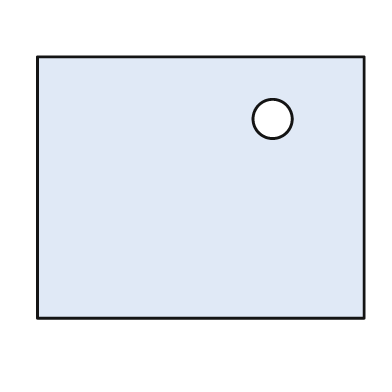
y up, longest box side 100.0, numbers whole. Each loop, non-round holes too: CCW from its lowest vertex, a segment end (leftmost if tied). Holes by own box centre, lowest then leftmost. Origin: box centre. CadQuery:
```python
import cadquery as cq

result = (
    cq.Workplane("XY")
    .moveTo(-50.0, -40.0)
    .lineTo(50.0, -40.0)
    .lineTo(50.0, 40.0)
    .lineTo(-50.0, 40.0)
    .close()
    .moveTo(22.0, 21.0)
    .circle(6.0)
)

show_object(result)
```